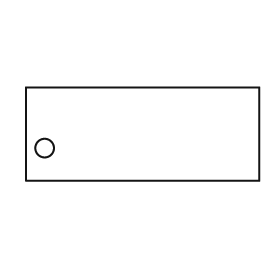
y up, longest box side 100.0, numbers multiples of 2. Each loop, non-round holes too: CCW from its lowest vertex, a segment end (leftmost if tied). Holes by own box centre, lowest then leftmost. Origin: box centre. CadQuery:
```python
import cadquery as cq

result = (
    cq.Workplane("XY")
    .moveTo(-50.0, -20.0)
    .lineTo(50.0, -20.0)
    .lineTo(50.0, 20.0)
    .lineTo(-50.0, 20.0)
    .close()
    .moveTo(-42.0, -6.0)
    .circle(4.0)
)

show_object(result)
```